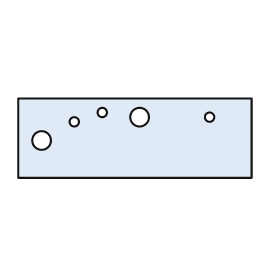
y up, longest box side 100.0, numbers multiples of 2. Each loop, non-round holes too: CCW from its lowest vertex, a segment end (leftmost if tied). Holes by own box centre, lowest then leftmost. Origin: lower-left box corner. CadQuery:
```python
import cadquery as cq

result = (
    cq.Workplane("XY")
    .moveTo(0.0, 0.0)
    .lineTo(100.0, 0.0)
    .lineTo(100.0, 34.0)
    .lineTo(0.0, 34.0)
    .close()
    .moveTo(10.0, 16.0)
    .circle(4.0)
    .moveTo(24.0, 24.0)
    .circle(2.0)
    .moveTo(52.0, 26.0)
    .circle(4.0)
    .moveTo(82.0, 26.0)
    .circle(2.0)
    .moveTo(36.0, 28.0)
    .circle(2.0)
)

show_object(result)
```